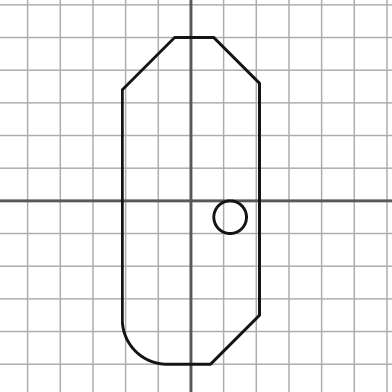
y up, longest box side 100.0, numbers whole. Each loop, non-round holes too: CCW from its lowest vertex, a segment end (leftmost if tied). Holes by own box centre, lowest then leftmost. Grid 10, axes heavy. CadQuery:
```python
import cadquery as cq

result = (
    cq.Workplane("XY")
    .moveTo(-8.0, -50.0)
    .lineTo(6.0, -50.0)
    .lineTo(21.0, -35.0)
    .lineTo(21.0, 36.0)
    .lineTo(7.0, 50.0)
    .lineTo(-5.0, 50.0)
    .lineTo(-21.0, 34.0)
    .lineTo(-21.0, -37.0)
    .threePointArc((-17.0, -46.0), (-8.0, -50.0))
    .close()
    .moveTo(12.0, -5.0)
    .circle(5.0)
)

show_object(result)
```